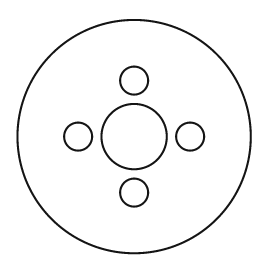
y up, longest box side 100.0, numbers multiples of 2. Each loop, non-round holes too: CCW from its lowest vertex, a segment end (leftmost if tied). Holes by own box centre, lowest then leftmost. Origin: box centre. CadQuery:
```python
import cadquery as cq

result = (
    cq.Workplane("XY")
    .moveTo(0.0, 0.0)
    .circle(50.0)
    .moveTo(0.0, -24.0)
    .circle(6.0)
    .moveTo(-24.0, 0.0)
    .circle(6.0)
    .moveTo(0.0, 0.0)
    .circle(14.0)
    .moveTo(24.0, 0.0)
    .circle(6.0)
    .moveTo(0.0, 24.0)
    .circle(6.0)
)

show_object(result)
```